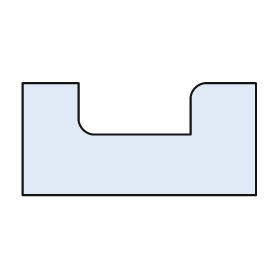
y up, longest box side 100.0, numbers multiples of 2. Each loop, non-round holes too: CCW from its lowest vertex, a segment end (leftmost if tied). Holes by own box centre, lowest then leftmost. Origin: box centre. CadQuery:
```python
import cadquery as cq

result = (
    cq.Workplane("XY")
    .moveTo(-50.0, -24.0)
    .lineTo(50.0, -24.0)
    .lineTo(50.0, 24.0)
    .lineTo(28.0, 24.0)
    .threePointArc((24.0, 22.0), (22.0, 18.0))
    .lineTo(22.0, 2.0)
    .lineTo(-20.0, 2.0)
    .threePointArc((-24.0, 4.0), (-26.0, 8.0))
    .lineTo(-26.0, 24.0)
    .lineTo(-50.0, 24.0)
    .close()
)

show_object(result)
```